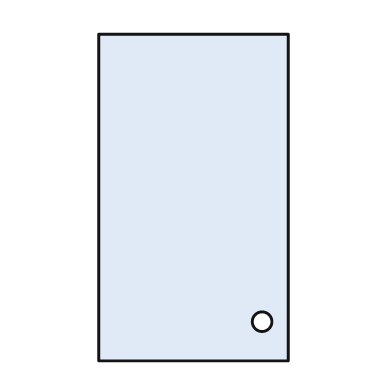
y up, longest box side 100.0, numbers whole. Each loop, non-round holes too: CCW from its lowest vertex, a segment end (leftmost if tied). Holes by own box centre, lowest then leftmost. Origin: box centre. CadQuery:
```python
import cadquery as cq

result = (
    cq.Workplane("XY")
    .moveTo(-29.0, -50.0)
    .lineTo(29.0, -50.0)
    .lineTo(29.0, 50.0)
    .lineTo(-29.0, 50.0)
    .close()
    .moveTo(21.0, -38.0)
    .circle(3.0)
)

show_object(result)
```